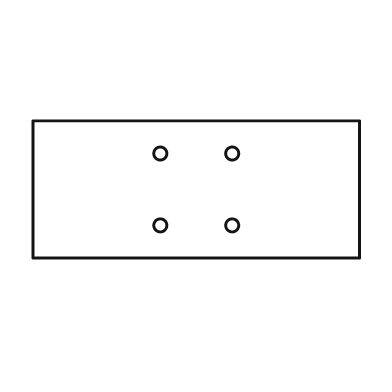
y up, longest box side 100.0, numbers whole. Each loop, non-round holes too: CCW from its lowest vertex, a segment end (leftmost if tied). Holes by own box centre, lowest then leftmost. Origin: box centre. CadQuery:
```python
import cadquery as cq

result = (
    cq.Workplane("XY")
    .moveTo(-50.0, -21.0)
    .lineTo(50.0, -21.0)
    .lineTo(50.0, 21.0)
    .lineTo(-50.0, 21.0)
    .close()
    .moveTo(-11.0, -11.0)
    .circle(2.0)
    .moveTo(11.0, -11.0)
    .circle(2.0)
    .moveTo(-11.0, 11.0)
    .circle(2.0)
    .moveTo(11.0, 11.0)
    .circle(2.0)
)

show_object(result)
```